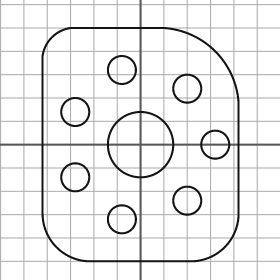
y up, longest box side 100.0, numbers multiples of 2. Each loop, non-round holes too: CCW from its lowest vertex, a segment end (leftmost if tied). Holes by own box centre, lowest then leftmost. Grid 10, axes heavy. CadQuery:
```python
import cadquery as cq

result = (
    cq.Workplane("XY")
    .moveTo(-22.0, -50.0)
    .lineTo(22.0, -50.0)
    .threePointArc((36.0, -44.0), (42.0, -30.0))
    .lineTo(42.0, 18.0)
    .threePointArc((32.0, 40.0), (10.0, 50.0))
    .lineTo(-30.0, 50.0)
    .threePointArc((-38.0, 46.0), (-42.0, 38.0))
    .lineTo(-42.0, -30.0)
    .threePointArc((-36.0, -44.0), (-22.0, -50.0))
    .close()
    .moveTo(-8.0, -32.0)
    .circle(6.0)
    .moveTo(20.0, -24.0)
    .circle(6.0)
    .moveTo(-28.0, -14.0)
    .circle(6.0)
    .moveTo(0.0, 0.0)
    .circle(14.0)
    .moveTo(32.0, 0.0)
    .circle(6.0)
    .moveTo(-28.0, 14.0)
    .circle(6.0)
    .moveTo(20.0, 24.0)
    .circle(6.0)
    .moveTo(-8.0, 32.0)
    .circle(6.0)
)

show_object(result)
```